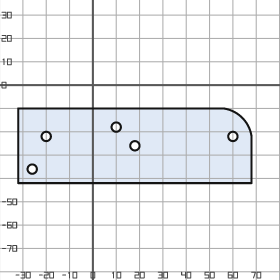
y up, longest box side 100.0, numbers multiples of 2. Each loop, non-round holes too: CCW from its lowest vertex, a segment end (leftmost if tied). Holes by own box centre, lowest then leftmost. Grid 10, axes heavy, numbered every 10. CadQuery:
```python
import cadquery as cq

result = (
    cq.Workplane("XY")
    .moveTo(-32.0, -42.0)
    .lineTo(68.0, -42.0)
    .lineTo(68.0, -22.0)
    .threePointArc((64.0, -14.0), (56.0, -10.0))
    .lineTo(-32.0, -10.0)
    .close()
    .moveTo(-26.0, -36.0)
    .circle(2.0)
    .moveTo(18.0, -26.0)
    .circle(2.0)
    .moveTo(-20.0, -22.0)
    .circle(2.0)
    .moveTo(60.0, -22.0)
    .circle(2.0)
    .moveTo(10.0, -18.0)
    .circle(2.0)
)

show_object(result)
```